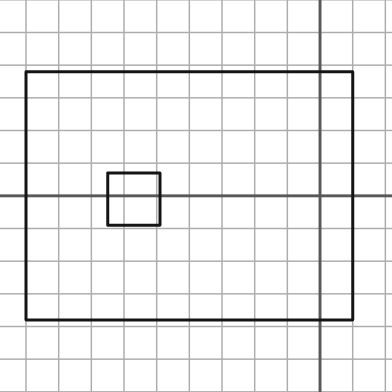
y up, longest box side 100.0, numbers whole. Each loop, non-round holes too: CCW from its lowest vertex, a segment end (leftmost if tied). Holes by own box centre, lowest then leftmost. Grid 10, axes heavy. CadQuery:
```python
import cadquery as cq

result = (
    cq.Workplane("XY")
    .moveTo(-90.0, -38.0)
    .lineTo(10.0, -38.0)
    .lineTo(10.0, 38.0)
    .lineTo(-90.0, 38.0)
    .close()
    .moveTo(-65.0, -9.0)
    .lineTo(-49.0, -9.0)
    .lineTo(-49.0, 7.0)
    .lineTo(-65.0, 7.0)
    .close()
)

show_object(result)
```